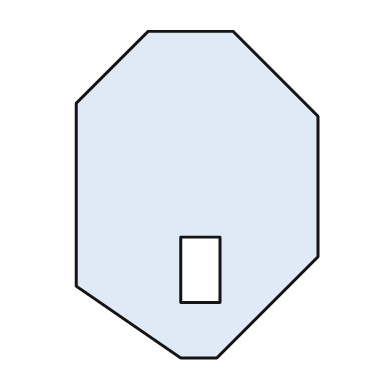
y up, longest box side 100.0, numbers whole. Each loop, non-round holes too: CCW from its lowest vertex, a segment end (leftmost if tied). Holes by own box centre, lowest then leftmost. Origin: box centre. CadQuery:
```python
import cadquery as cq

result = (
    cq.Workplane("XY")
    .moveTo(-5.0, -50.0)
    .lineTo(6.0, -50.0)
    .lineTo(37.0, -19.0)
    .lineTo(37.0, 24.0)
    .lineTo(11.0, 50.0)
    .lineTo(-15.0, 50.0)
    .lineTo(-37.0, 28.0)
    .lineTo(-37.0, -28.0)
    .close()
    .moveTo(-5.0, -33.0)
    .lineTo(7.0, -33.0)
    .lineTo(7.0, -13.0)
    .lineTo(-5.0, -13.0)
    .close()
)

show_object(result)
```